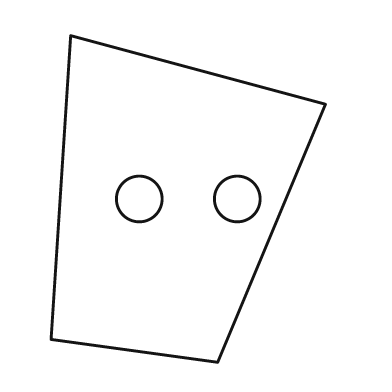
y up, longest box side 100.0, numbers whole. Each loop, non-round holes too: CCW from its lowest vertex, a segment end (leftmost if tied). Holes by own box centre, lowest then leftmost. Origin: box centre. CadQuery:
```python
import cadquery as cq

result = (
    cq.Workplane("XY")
    .moveTo(9.0, -50.0)
    .lineTo(42.0, 29.0)
    .lineTo(-36.0, 50.0)
    .lineTo(-42.0, -43.0)
    .close()
    .moveTo(-15.0, 0.0)
    .circle(7.0)
    .moveTo(15.0, 0.0)
    .circle(7.0)
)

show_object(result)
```